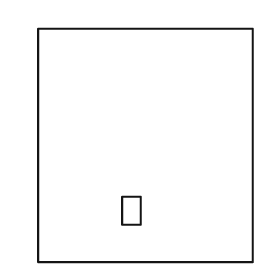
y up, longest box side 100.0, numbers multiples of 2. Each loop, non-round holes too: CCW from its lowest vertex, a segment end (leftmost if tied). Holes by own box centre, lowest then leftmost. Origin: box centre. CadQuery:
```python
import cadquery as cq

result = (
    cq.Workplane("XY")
    .moveTo(-46.0, -50.0)
    .lineTo(46.0, -50.0)
    .lineTo(46.0, 50.0)
    .lineTo(-46.0, 50.0)
    .close()
    .moveTo(-10.0, -34.0)
    .lineTo(-2.0, -34.0)
    .lineTo(-2.0, -22.0)
    .lineTo(-10.0, -22.0)
    .close()
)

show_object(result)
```